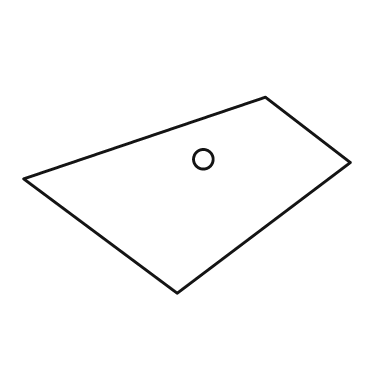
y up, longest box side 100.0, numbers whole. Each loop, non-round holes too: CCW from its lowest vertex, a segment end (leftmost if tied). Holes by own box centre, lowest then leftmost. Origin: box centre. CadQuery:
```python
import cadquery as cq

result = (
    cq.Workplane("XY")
    .moveTo(-3.0, -30.0)
    .lineTo(50.0, 10.0)
    .lineTo(24.0, 30.0)
    .lineTo(-50.0, 5.0)
    .close()
    .moveTo(5.0, 11.0)
    .circle(3.0)
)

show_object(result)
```